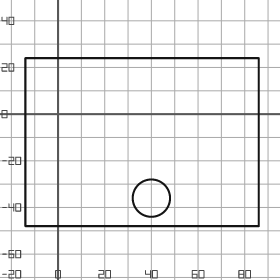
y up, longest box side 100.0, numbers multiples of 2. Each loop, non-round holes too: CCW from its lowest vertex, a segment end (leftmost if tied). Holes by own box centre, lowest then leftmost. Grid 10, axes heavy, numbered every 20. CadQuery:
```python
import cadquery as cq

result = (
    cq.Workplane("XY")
    .moveTo(-14.0, -48.0)
    .lineTo(86.0, -48.0)
    .lineTo(86.0, 24.0)
    .lineTo(-14.0, 24.0)
    .close()
    .moveTo(40.0, -36.0)
    .circle(8.0)
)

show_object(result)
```